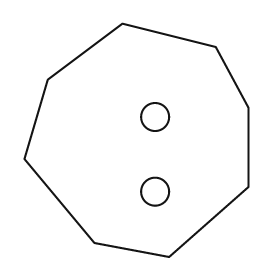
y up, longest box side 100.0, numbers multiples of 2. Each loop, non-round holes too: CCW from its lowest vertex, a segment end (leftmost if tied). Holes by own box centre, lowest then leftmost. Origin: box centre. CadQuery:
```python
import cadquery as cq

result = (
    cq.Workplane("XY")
    .moveTo(14.0, -50.0)
    .lineTo(48.0, -20.0)
    .lineTo(48.0, 14.0)
    .lineTo(34.0, 40.0)
    .lineTo(-6.0, 50.0)
    .lineTo(-38.0, 26.0)
    .lineTo(-48.0, -8.0)
    .lineTo(-18.0, -44.0)
    .close()
    .moveTo(8.0, -22.0)
    .circle(6.0)
    .moveTo(8.0, 10.0)
    .circle(6.0)
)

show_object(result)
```